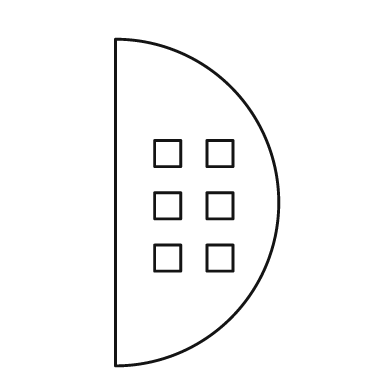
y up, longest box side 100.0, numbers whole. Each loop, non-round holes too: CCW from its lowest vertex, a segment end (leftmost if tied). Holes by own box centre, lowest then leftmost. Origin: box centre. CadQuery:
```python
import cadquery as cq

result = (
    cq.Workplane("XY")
    .moveTo(-25.0, -50.0)
    .threePointArc((25.0, 0.0), (-25.0, 50.0))
    .close()
    .moveTo(-13.0, -21.0)
    .lineTo(-5.0, -21.0)
    .lineTo(-5.0, -13.0)
    .lineTo(-13.0, -13.0)
    .close()
    .moveTo(3.0, -21.0)
    .lineTo(11.0, -21.0)
    .lineTo(11.0, -13.0)
    .lineTo(3.0, -13.0)
    .close()
    .moveTo(-13.0, -5.0)
    .lineTo(-5.0, -5.0)
    .lineTo(-5.0, 3.0)
    .lineTo(-13.0, 3.0)
    .close()
    .moveTo(3.0, -5.0)
    .lineTo(11.0, -5.0)
    .lineTo(11.0, 3.0)
    .lineTo(3.0, 3.0)
    .close()
    .moveTo(-13.0, 11.0)
    .lineTo(-5.0, 11.0)
    .lineTo(-5.0, 19.0)
    .lineTo(-13.0, 19.0)
    .close()
    .moveTo(3.0, 11.0)
    .lineTo(11.0, 11.0)
    .lineTo(11.0, 19.0)
    .lineTo(3.0, 19.0)
    .close()
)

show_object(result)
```